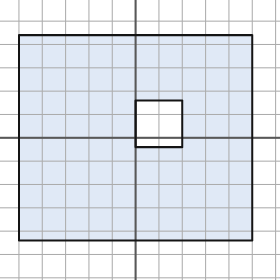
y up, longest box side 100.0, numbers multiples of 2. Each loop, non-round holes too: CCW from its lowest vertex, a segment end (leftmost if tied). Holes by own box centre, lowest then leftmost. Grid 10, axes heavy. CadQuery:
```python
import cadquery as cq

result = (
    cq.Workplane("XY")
    .moveTo(-50.0, -44.0)
    .lineTo(50.0, -44.0)
    .lineTo(50.0, 44.0)
    .lineTo(-50.0, 44.0)
    .close()
    .moveTo(0.0, -4.0)
    .lineTo(20.0, -4.0)
    .lineTo(20.0, 16.0)
    .lineTo(0.0, 16.0)
    .close()
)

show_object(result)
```